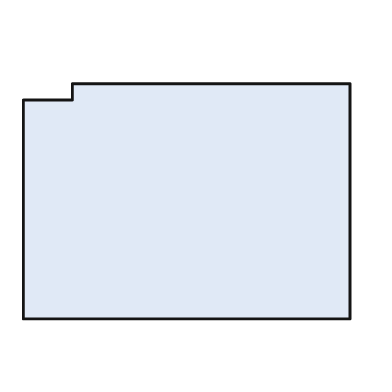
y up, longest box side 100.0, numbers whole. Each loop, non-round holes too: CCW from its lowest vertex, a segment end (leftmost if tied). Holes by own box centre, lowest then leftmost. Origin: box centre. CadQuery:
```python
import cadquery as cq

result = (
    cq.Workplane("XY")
    .moveTo(-50.0, -36.0)
    .lineTo(50.0, -36.0)
    .lineTo(50.0, 36.0)
    .lineTo(-35.0, 36.0)
    .lineTo(-35.0, 31.0)
    .lineTo(-50.0, 31.0)
    .close()
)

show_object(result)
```